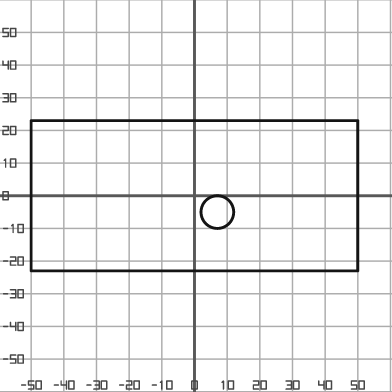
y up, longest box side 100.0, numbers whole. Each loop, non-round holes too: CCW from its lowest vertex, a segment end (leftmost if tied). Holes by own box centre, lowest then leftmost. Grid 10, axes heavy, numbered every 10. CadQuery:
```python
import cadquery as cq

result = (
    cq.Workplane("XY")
    .moveTo(-50.0, -23.0)
    .lineTo(50.0, -23.0)
    .lineTo(50.0, 23.0)
    .lineTo(-50.0, 23.0)
    .close()
    .moveTo(7.0, -5.0)
    .circle(5.0)
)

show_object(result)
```